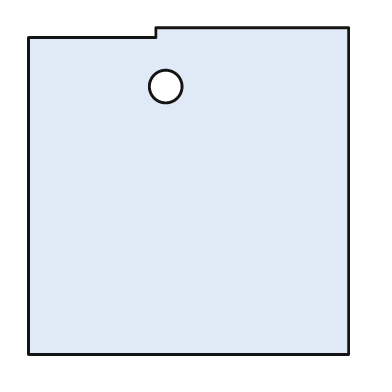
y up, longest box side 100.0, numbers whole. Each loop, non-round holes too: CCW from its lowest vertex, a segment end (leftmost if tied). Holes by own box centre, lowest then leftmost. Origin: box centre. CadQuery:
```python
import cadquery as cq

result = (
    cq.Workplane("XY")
    .moveTo(-49.0, -50.0)
    .lineTo(49.0, -50.0)
    .lineTo(49.0, 50.0)
    .lineTo(-10.0, 50.0)
    .lineTo(-10.0, 47.0)
    .lineTo(-49.0, 47.0)
    .close()
    .moveTo(-7.0, 32.0)
    .circle(5.0)
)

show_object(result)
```